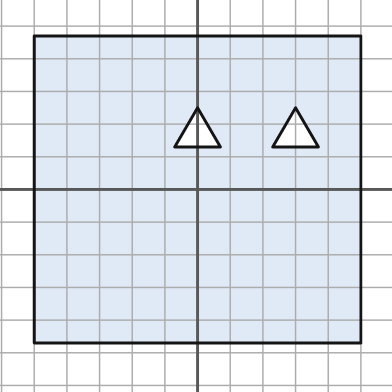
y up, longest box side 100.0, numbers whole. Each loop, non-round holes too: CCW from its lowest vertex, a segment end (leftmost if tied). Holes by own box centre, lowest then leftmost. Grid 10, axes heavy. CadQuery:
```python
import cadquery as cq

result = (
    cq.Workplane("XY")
    .moveTo(-50.0, -47.0)
    .lineTo(50.0, -47.0)
    .lineTo(50.0, 47.0)
    .lineTo(-50.0, 47.0)
    .close()
    .moveTo(-7.0, 13.0)
    .lineTo(7.0, 13.0)
    .lineTo(0.0, 25.0)
    .close()
    .moveTo(23.0, 13.0)
    .lineTo(37.0, 13.0)
    .lineTo(30.0, 25.0)
    .close()
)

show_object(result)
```